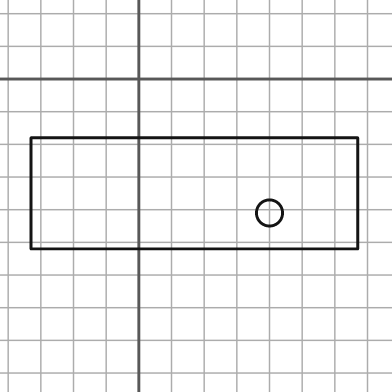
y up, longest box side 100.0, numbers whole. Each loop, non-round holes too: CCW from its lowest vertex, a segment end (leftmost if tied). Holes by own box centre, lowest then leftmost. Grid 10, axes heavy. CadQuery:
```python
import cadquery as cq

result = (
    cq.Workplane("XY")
    .moveTo(-33.0, -52.0)
    .lineTo(67.0, -52.0)
    .lineTo(67.0, -18.0)
    .lineTo(-33.0, -18.0)
    .close()
    .moveTo(40.0, -41.0)
    .circle(4.0)
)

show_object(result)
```